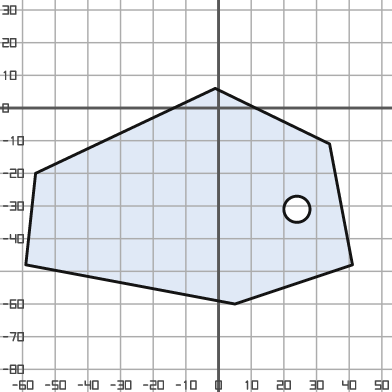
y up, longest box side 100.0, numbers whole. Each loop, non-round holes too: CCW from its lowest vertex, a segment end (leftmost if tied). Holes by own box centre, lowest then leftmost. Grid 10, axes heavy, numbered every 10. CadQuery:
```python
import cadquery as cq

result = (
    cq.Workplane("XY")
    .moveTo(5.0, -60.0)
    .lineTo(41.0, -48.0)
    .lineTo(34.0, -11.0)
    .lineTo(-1.0, 6.0)
    .lineTo(-56.0, -20.0)
    .lineTo(-59.0, -48.0)
    .close()
    .moveTo(24.0, -31.0)
    .circle(4.0)
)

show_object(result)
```